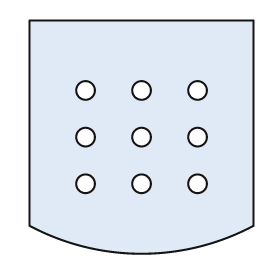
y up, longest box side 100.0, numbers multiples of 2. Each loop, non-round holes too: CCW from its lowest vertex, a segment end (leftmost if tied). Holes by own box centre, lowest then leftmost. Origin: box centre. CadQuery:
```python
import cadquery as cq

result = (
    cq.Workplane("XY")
    .moveTo(-48.0, -38.0)
    .threePointArc((0.0, -50.0), (48.0, -38.0))
    .lineTo(48.0, 50.0)
    .lineTo(-48.0, 50.0)
    .close()
    .moveTo(-24.0, -20.0)
    .circle(4.0)
    .moveTo(0.0, -20.0)
    .circle(4.0)
    .moveTo(24.0, -20.0)
    .circle(4.0)
    .moveTo(-24.0, 0.0)
    .circle(4.0)
    .moveTo(0.0, 0.0)
    .circle(4.0)
    .moveTo(24.0, 0.0)
    .circle(4.0)
    .moveTo(-24.0, 20.0)
    .circle(4.0)
    .moveTo(0.0, 20.0)
    .circle(4.0)
    .moveTo(24.0, 20.0)
    .circle(4.0)
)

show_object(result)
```